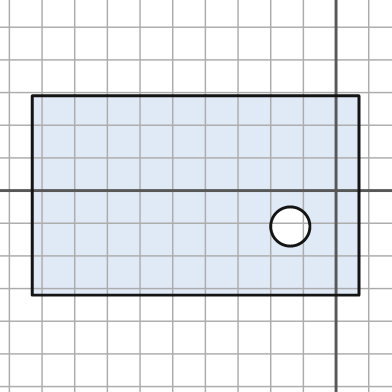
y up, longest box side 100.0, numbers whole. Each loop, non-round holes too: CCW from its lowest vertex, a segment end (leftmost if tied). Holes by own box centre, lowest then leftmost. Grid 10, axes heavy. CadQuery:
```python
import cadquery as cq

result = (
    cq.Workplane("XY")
    .moveTo(-93.0, -32.0)
    .lineTo(7.0, -32.0)
    .lineTo(7.0, 29.0)
    .lineTo(-93.0, 29.0)
    .close()
    .moveTo(-14.0, -11.0)
    .circle(6.0)
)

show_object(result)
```